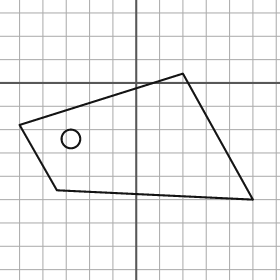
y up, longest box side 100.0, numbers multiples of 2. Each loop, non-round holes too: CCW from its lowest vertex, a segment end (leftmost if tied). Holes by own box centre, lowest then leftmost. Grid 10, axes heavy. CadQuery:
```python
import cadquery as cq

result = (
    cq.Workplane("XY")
    .moveTo(50.0, -50.0)
    .lineTo(20.0, 4.0)
    .lineTo(-50.0, -18.0)
    .lineTo(-34.0, -46.0)
    .close()
    .moveTo(-28.0, -24.0)
    .circle(4.0)
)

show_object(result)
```